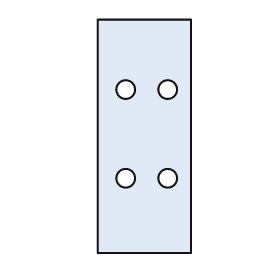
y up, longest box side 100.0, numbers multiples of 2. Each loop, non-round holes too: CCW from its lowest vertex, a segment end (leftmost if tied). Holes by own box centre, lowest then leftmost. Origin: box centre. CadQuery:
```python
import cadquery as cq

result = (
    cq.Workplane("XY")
    .moveTo(-20.0, -50.0)
    .lineTo(20.0, -50.0)
    .lineTo(20.0, 50.0)
    .lineTo(-20.0, 50.0)
    .close()
    .moveTo(-8.0, -18.0)
    .circle(4.0)
    .moveTo(10.0, -18.0)
    .circle(4.0)
    .moveTo(-8.0, 20.0)
    .circle(4.0)
    .moveTo(10.0, 20.0)
    .circle(4.0)
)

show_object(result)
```